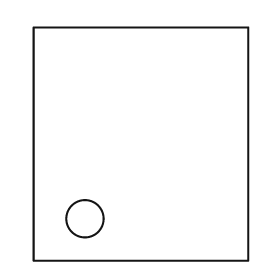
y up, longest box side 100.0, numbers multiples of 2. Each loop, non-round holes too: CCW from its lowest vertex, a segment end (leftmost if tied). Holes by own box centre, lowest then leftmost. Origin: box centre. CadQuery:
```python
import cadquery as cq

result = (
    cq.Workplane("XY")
    .moveTo(-46.0, -50.0)
    .lineTo(46.0, -50.0)
    .lineTo(46.0, 50.0)
    .lineTo(-46.0, 50.0)
    .close()
    .moveTo(-24.0, -32.0)
    .circle(8.0)
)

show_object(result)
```